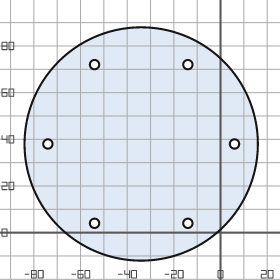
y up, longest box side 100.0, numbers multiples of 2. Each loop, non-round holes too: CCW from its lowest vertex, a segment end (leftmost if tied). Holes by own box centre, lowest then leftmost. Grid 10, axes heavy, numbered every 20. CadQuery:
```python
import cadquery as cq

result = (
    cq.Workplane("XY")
    .moveTo(-34.0, 38.0)
    .circle(50.0)
    .moveTo(-54.0, 4.0)
    .circle(2.0)
    .moveTo(-14.0, 4.0)
    .circle(2.0)
    .moveTo(-74.0, 38.0)
    .circle(2.0)
    .moveTo(6.0, 38.0)
    .circle(2.0)
    .moveTo(-54.0, 72.0)
    .circle(2.0)
    .moveTo(-14.0, 72.0)
    .circle(2.0)
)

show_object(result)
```